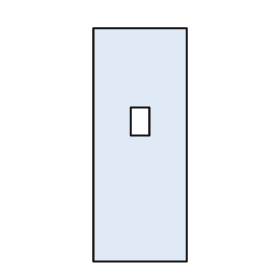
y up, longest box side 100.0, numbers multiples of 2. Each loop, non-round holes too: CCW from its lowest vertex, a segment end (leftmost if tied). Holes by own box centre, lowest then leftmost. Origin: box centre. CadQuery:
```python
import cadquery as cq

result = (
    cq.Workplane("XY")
    .moveTo(-20.0, -50.0)
    .lineTo(20.0, -50.0)
    .lineTo(20.0, 50.0)
    .lineTo(-20.0, 50.0)
    .close()
    .moveTo(-4.0, 4.0)
    .lineTo(4.0, 4.0)
    .lineTo(4.0, 16.0)
    .lineTo(-4.0, 16.0)
    .close()
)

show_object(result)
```